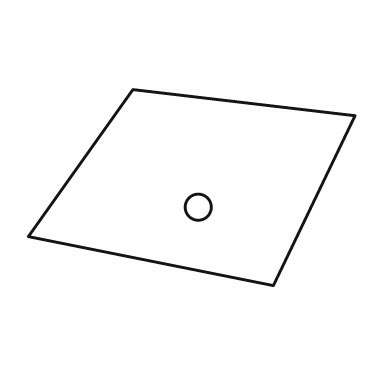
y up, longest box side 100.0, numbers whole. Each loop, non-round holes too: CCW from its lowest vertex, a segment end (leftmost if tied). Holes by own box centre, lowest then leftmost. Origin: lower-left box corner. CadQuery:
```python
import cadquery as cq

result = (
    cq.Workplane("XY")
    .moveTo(75.0, 0.0)
    .lineTo(100.0, 52.0)
    .lineTo(32.0, 60.0)
    .lineTo(0.0, 15.0)
    .close()
    .moveTo(52.0, 24.0)
    .circle(4.0)
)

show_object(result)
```